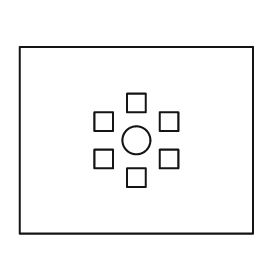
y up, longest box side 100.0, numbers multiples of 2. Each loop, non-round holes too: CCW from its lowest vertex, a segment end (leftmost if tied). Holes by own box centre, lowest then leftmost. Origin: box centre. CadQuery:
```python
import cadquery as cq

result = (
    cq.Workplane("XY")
    .moveTo(-50.0, -40.0)
    .lineTo(50.0, -40.0)
    .lineTo(50.0, 40.0)
    .lineTo(-50.0, 40.0)
    .close()
    .moveTo(-4.0, -20.0)
    .lineTo(4.0, -20.0)
    .lineTo(4.0, -12.0)
    .lineTo(-4.0, -12.0)
    .close()
    .moveTo(-18.0, -12.0)
    .lineTo(-10.0, -12.0)
    .lineTo(-10.0, -4.0)
    .lineTo(-18.0, -4.0)
    .close()
    .moveTo(10.0, -12.0)
    .lineTo(18.0, -12.0)
    .lineTo(18.0, -4.0)
    .lineTo(10.0, -4.0)
    .close()
    .moveTo(0.0, 0.0)
    .circle(6.0)
    .moveTo(-18.0, 4.0)
    .lineTo(-10.0, 4.0)
    .lineTo(-10.0, 12.0)
    .lineTo(-18.0, 12.0)
    .close()
    .moveTo(10.0, 4.0)
    .lineTo(18.0, 4.0)
    .lineTo(18.0, 12.0)
    .lineTo(10.0, 12.0)
    .close()
    .moveTo(-4.0, 12.0)
    .lineTo(4.0, 12.0)
    .lineTo(4.0, 20.0)
    .lineTo(-4.0, 20.0)
    .close()
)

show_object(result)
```